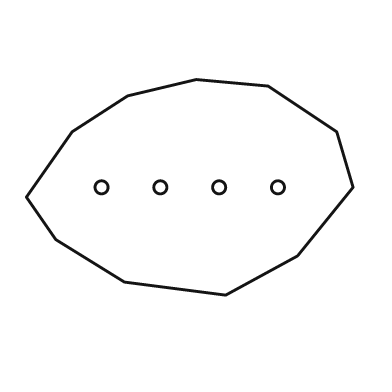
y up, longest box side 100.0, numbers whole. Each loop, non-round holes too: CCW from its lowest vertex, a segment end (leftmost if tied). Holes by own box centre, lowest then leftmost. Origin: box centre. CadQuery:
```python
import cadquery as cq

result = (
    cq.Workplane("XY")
    .moveTo(11.0, -33.0)
    .lineTo(33.0, -21.0)
    .lineTo(50.0, 0.0)
    .lineTo(45.0, 17.0)
    .lineTo(24.0, 31.0)
    .lineTo(2.0, 33.0)
    .lineTo(-19.0, 28.0)
    .lineTo(-36.0, 17.0)
    .lineTo(-50.0, -3.0)
    .lineTo(-41.0, -16.0)
    .lineTo(-20.0, -29.0)
    .close()
    .moveTo(-27.0, 0.0)
    .circle(2.0)
    .moveTo(-9.0, 0.0)
    .circle(2.0)
    .moveTo(9.0, 0.0)
    .circle(2.0)
    .moveTo(27.0, 0.0)
    .circle(2.0)
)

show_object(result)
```